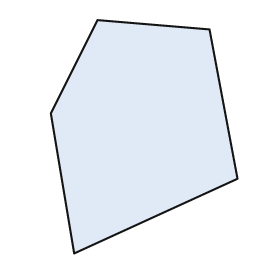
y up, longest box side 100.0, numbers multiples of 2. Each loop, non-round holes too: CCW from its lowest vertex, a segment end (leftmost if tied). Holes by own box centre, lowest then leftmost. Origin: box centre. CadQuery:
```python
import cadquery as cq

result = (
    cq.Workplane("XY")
    .moveTo(-30.0, -50.0)
    .lineTo(40.0, -18.0)
    .lineTo(28.0, 46.0)
    .lineTo(-20.0, 50.0)
    .lineTo(-40.0, 10.0)
    .close()
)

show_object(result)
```